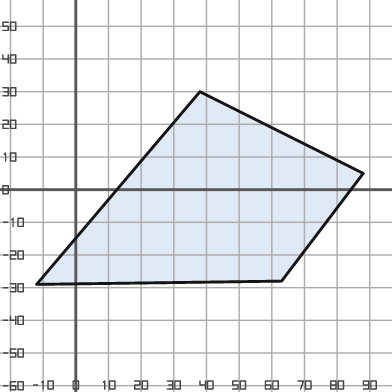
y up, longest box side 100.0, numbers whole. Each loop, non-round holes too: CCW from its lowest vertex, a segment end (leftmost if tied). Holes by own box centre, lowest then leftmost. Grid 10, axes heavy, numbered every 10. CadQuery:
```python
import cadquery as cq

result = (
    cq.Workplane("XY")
    .moveTo(-12.0, -29.0)
    .lineTo(63.0, -28.0)
    .lineTo(88.0, 5.0)
    .lineTo(38.0, 30.0)
    .close()
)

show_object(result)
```